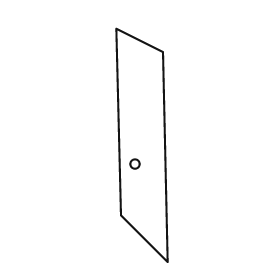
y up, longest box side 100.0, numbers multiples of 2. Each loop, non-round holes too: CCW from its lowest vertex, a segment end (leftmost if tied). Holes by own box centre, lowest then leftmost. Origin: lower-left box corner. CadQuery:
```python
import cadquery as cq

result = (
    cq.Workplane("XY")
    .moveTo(22.0, 0.0)
    .lineTo(20.0, 90.0)
    .lineTo(0.0, 100.0)
    .lineTo(2.0, 20.0)
    .close()
    .moveTo(8.0, 42.0)
    .circle(2.0)
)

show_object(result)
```